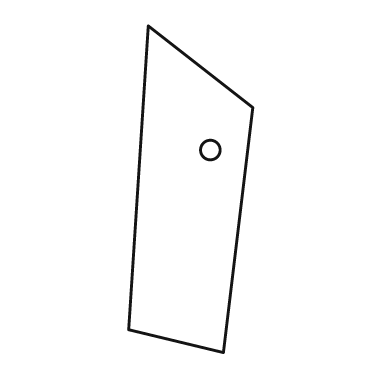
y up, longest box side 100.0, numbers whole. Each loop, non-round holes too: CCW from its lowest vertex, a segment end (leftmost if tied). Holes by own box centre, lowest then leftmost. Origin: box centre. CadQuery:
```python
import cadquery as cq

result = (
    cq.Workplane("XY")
    .moveTo(10.0, -50.0)
    .lineTo(19.0, 25.0)
    .lineTo(-13.0, 50.0)
    .lineTo(-19.0, -43.0)
    .close()
    .moveTo(6.0, 12.0)
    .circle(3.0)
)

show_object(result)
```